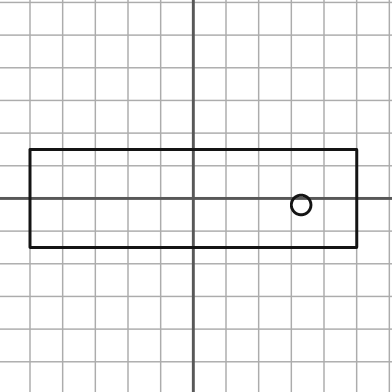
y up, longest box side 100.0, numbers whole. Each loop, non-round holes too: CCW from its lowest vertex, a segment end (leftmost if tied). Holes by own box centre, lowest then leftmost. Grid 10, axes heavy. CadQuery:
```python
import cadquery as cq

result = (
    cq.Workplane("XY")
    .moveTo(-50.0, -15.0)
    .lineTo(50.0, -15.0)
    .lineTo(50.0, 15.0)
    .lineTo(-50.0, 15.0)
    .close()
    .moveTo(33.0, -2.0)
    .circle(3.0)
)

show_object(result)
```